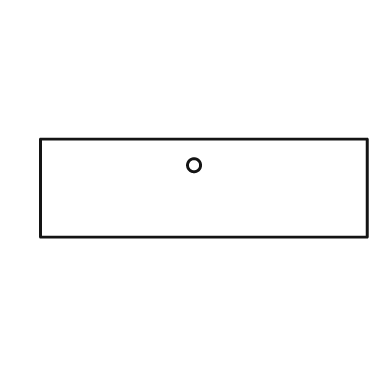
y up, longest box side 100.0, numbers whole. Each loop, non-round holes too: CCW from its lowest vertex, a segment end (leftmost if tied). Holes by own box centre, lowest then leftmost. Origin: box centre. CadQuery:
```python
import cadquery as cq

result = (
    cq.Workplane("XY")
    .moveTo(-50.0, -15.0)
    .lineTo(50.0, -15.0)
    .lineTo(50.0, 15.0)
    .lineTo(-50.0, 15.0)
    .close()
    .moveTo(-3.0, 7.0)
    .circle(2.0)
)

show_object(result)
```